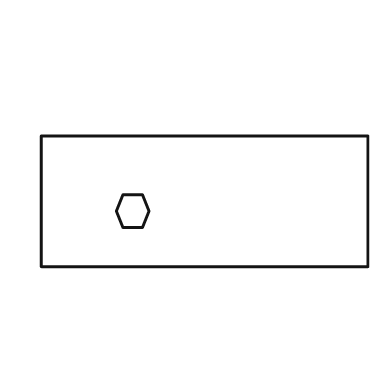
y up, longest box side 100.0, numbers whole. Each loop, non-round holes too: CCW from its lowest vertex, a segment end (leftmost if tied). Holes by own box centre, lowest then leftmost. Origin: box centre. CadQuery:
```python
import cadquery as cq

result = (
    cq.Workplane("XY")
    .moveTo(-50.0, -20.0)
    .lineTo(50.0, -20.0)
    .lineTo(50.0, 20.0)
    .lineTo(-50.0, 20.0)
    .close()
    .moveTo(-25.0, -8.0)
    .lineTo(-19.0, -8.0)
    .lineTo(-17.0, -3.0)
    .lineTo(-19.0, 2.0)
    .lineTo(-25.0, 2.0)
    .lineTo(-27.0, -3.0)
    .close()
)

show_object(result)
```